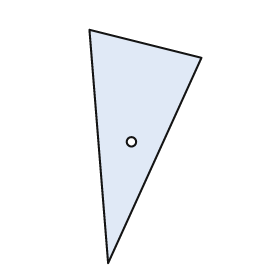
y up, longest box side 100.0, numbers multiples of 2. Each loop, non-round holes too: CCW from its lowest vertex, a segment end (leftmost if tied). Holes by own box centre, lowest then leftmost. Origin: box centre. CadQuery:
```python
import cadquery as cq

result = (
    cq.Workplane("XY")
    .moveTo(-16.0, -50.0)
    .lineTo(24.0, 38.0)
    .lineTo(-24.0, 50.0)
    .close()
    .moveTo(-6.0, 2.0)
    .circle(2.0)
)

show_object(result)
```